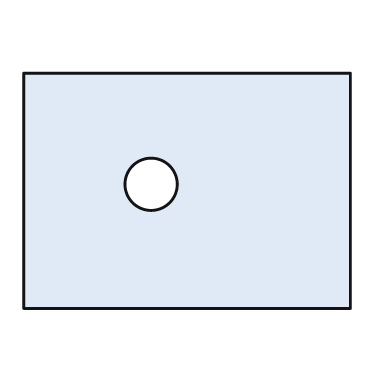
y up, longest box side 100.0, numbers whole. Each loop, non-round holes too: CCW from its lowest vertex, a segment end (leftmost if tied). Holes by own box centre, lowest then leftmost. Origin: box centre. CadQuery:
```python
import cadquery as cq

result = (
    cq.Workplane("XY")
    .moveTo(-50.0, -36.0)
    .lineTo(50.0, -36.0)
    .lineTo(50.0, 36.0)
    .lineTo(-50.0, 36.0)
    .close()
    .moveTo(-11.0, 2.0)
    .circle(8.0)
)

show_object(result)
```